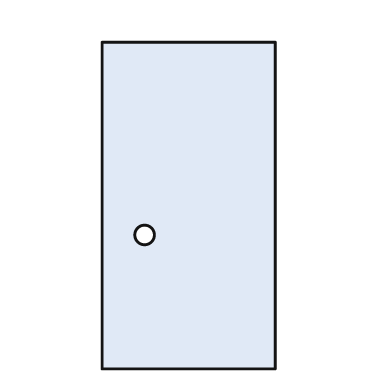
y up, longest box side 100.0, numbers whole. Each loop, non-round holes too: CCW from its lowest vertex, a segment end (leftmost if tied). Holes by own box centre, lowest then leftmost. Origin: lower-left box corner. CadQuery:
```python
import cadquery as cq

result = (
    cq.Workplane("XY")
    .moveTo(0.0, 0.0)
    .lineTo(53.0, 0.0)
    .lineTo(53.0, 100.0)
    .lineTo(0.0, 100.0)
    .close()
    .moveTo(13.0, 41.0)
    .circle(3.0)
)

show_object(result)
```